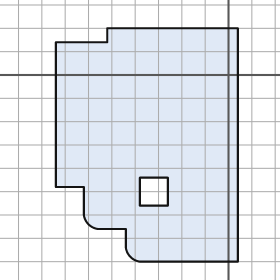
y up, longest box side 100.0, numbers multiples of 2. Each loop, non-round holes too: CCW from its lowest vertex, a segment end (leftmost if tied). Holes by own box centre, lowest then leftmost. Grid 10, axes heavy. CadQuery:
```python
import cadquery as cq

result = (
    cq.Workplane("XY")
    .moveTo(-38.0, -80.0)
    .lineTo(4.0, -80.0)
    .lineTo(4.0, 20.0)
    .lineTo(-52.0, 20.0)
    .lineTo(-52.0, 14.0)
    .lineTo(-74.0, 14.0)
    .lineTo(-74.0, -48.0)
    .lineTo(-62.0, -48.0)
    .lineTo(-62.0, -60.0)
    .threePointArc((-60.0, -64.0), (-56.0, -66.0))
    .lineTo(-44.0, -66.0)
    .lineTo(-44.0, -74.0)
    .threePointArc((-42.0, -78.0), (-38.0, -80.0))
    .close()
    .moveTo(-38.0, -56.0)
    .lineTo(-26.0, -56.0)
    .lineTo(-26.0, -44.0)
    .lineTo(-38.0, -44.0)
    .close()
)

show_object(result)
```